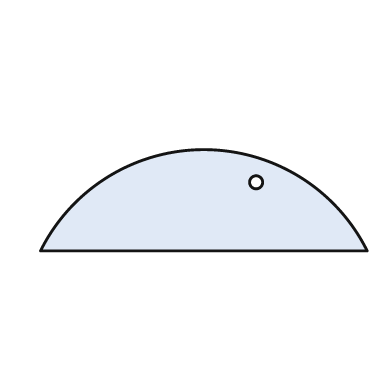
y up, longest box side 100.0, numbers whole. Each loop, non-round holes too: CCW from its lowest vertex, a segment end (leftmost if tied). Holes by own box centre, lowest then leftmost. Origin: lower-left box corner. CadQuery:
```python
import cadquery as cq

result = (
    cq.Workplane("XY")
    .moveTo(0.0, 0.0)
    .lineTo(100.0, 0.0)
    .threePointArc((50.0, 31.0), (0.0, 0.0))
    .close()
    .moveTo(66.0, 21.0)
    .circle(2.0)
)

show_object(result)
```